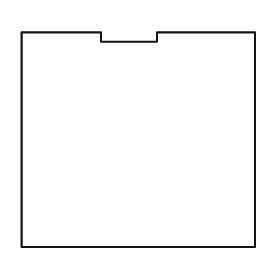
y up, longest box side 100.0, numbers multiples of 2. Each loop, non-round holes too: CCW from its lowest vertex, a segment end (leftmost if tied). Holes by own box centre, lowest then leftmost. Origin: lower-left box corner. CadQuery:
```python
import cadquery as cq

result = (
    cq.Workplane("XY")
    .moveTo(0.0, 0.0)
    .lineTo(100.0, 0.0)
    .lineTo(100.0, 92.0)
    .lineTo(58.0, 92.0)
    .lineTo(58.0, 88.0)
    .lineTo(34.0, 88.0)
    .lineTo(34.0, 92.0)
    .lineTo(0.0, 92.0)
    .close()
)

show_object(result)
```